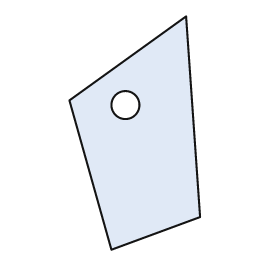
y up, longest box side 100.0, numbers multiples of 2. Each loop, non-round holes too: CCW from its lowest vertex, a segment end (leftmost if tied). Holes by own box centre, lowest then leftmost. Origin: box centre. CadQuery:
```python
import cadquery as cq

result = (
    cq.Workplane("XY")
    .moveTo(-10.0, -50.0)
    .lineTo(28.0, -36.0)
    .lineTo(22.0, 50.0)
    .lineTo(-28.0, 14.0)
    .close()
    .moveTo(-4.0, 12.0)
    .circle(6.0)
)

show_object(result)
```